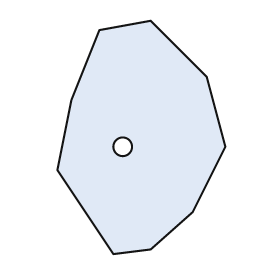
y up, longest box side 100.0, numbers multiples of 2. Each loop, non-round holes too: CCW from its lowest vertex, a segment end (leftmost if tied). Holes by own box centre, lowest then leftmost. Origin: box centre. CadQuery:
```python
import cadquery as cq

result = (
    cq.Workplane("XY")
    .moveTo(-12.0, -50.0)
    .lineTo(4.0, -48.0)
    .lineTo(22.0, -32.0)
    .lineTo(36.0, -4.0)
    .lineTo(28.0, 26.0)
    .lineTo(4.0, 50.0)
    .lineTo(-18.0, 46.0)
    .lineTo(-30.0, 16.0)
    .lineTo(-36.0, -14.0)
    .close()
    .moveTo(-8.0, -4.0)
    .circle(4.0)
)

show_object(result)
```